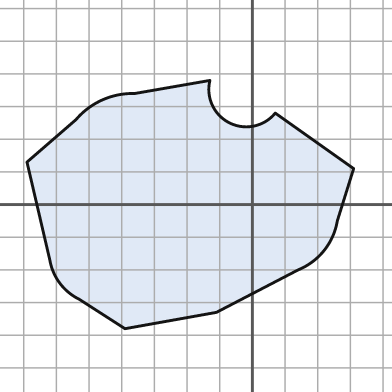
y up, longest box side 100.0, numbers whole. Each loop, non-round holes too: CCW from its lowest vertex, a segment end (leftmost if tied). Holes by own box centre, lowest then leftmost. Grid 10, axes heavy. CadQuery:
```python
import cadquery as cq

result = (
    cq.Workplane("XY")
    .moveTo(-39.0, -38.0)
    .lineTo(-11.0, -33.0)
    .lineTo(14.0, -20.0)
    .threePointArc((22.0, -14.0), (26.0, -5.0))
    .lineTo(31.0, 11.0)
    .lineTo(7.0, 28.0)
    .threePointArc((-7.0, 25.0), (-13.0, 38.0))
    .lineTo(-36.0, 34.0)
    .threePointArc((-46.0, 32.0), (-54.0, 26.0))
    .lineTo(-69.0, 13.0)
    .lineTo(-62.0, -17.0)
    .threePointArc((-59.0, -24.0), (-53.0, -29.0))
    .close()
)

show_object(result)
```